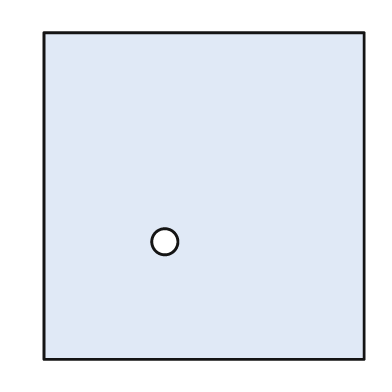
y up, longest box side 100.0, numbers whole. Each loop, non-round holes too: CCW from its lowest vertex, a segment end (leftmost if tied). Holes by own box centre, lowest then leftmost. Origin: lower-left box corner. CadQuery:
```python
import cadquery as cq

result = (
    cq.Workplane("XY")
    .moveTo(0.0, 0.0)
    .lineTo(98.0, 0.0)
    .lineTo(98.0, 100.0)
    .lineTo(0.0, 100.0)
    .close()
    .moveTo(37.0, 36.0)
    .circle(4.0)
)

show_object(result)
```